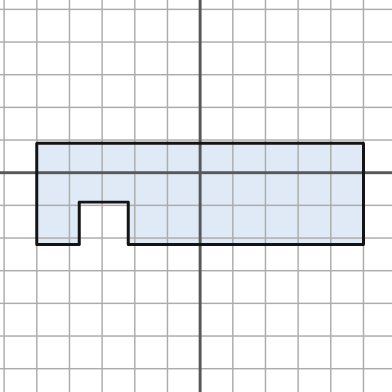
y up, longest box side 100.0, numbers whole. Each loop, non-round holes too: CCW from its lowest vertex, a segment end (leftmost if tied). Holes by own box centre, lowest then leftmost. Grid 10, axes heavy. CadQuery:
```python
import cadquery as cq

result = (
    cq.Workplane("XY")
    .moveTo(-50.0, -22.0)
    .lineTo(-37.0, -22.0)
    .lineTo(-37.0, -9.0)
    .lineTo(-22.0, -9.0)
    .lineTo(-22.0, -22.0)
    .lineTo(50.0, -22.0)
    .lineTo(50.0, 9.0)
    .lineTo(-50.0, 9.0)
    .close()
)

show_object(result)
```